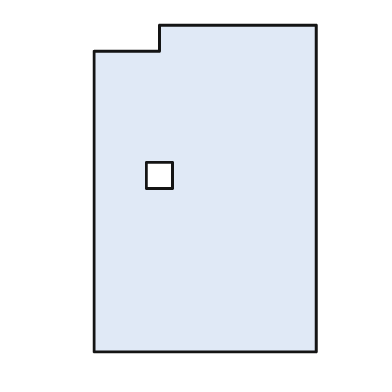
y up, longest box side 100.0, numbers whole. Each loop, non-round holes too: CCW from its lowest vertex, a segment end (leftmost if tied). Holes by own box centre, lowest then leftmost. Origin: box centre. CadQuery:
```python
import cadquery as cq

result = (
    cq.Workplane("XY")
    .moveTo(-34.0, -50.0)
    .lineTo(34.0, -50.0)
    .lineTo(34.0, 50.0)
    .lineTo(-14.0, 50.0)
    .lineTo(-14.0, 42.0)
    .lineTo(-34.0, 42.0)
    .close()
    .moveTo(-18.0, 0.0)
    .lineTo(-10.0, 0.0)
    .lineTo(-10.0, 8.0)
    .lineTo(-18.0, 8.0)
    .close()
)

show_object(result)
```